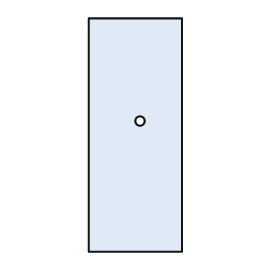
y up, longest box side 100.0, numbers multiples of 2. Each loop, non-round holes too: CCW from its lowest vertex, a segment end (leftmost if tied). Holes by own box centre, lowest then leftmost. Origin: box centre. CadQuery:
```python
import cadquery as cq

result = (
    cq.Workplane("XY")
    .moveTo(-20.0, -50.0)
    .lineTo(20.0, -50.0)
    .lineTo(20.0, 50.0)
    .lineTo(-20.0, 50.0)
    .close()
    .moveTo(2.0, 6.0)
    .circle(2.0)
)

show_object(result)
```